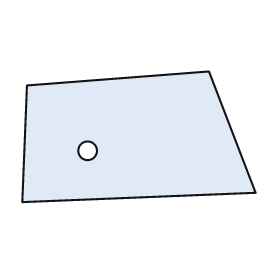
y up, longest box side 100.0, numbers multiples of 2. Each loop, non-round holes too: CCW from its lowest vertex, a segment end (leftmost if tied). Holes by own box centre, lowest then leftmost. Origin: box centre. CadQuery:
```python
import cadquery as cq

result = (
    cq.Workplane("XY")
    .moveTo(-50.0, -28.0)
    .lineTo(50.0, -24.0)
    .lineTo(30.0, 28.0)
    .lineTo(-48.0, 22.0)
    .close()
    .moveTo(-22.0, -6.0)
    .circle(4.0)
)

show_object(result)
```